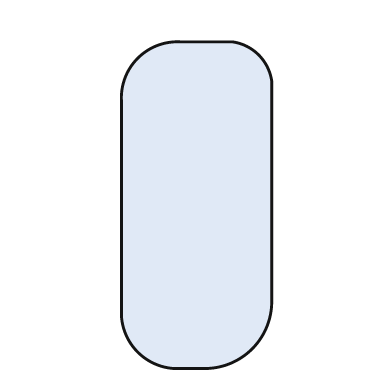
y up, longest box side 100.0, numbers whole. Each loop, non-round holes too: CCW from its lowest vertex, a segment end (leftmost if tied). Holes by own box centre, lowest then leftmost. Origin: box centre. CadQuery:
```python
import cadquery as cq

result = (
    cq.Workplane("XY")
    .moveTo(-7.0, -50.0)
    .lineTo(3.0, -50.0)
    .threePointArc((17.0, -44.0), (23.0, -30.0))
    .lineTo(23.0, 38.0)
    .threePointArc((19.0, 46.0), (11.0, 50.0))
    .lineTo(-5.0, 50.0)
    .threePointArc((-18.0, 45.0), (-23.0, 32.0))
    .lineTo(-23.0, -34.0)
    .threePointArc((-18.0, -45.0), (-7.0, -50.0))
    .close()
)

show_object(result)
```